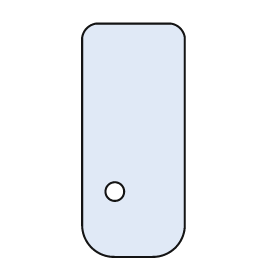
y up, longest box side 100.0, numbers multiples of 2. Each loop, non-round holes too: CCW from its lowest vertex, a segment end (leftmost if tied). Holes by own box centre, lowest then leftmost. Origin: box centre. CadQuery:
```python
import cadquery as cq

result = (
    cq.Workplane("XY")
    .moveTo(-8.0, -50.0)
    .lineTo(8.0, -50.0)
    .threePointArc((18.0, -46.0), (22.0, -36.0))
    .lineTo(22.0, 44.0)
    .threePointArc((20.0, 48.0), (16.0, 50.0))
    .lineTo(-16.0, 50.0)
    .threePointArc((-20.0, 48.0), (-22.0, 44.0))
    .lineTo(-22.0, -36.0)
    .threePointArc((-18.0, -46.0), (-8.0, -50.0))
    .close()
    .moveTo(-8.0, -22.0)
    .circle(4.0)
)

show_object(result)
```